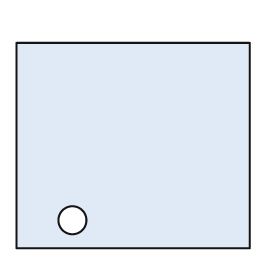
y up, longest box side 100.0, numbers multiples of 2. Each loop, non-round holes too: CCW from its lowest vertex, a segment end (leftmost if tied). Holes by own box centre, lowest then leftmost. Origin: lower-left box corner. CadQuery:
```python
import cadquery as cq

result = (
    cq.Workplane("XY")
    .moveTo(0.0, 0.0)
    .lineTo(100.0, 0.0)
    .lineTo(100.0, 88.0)
    .lineTo(0.0, 88.0)
    .close()
    .moveTo(24.0, 12.0)
    .circle(6.0)
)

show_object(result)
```